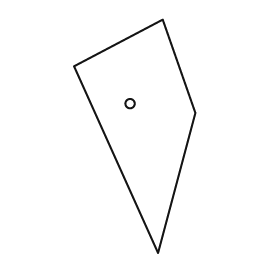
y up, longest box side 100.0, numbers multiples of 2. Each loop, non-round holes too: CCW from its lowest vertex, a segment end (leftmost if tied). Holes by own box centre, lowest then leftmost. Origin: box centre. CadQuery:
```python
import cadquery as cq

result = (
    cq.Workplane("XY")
    .moveTo(10.0, -50.0)
    .lineTo(26.0, 10.0)
    .lineTo(12.0, 50.0)
    .lineTo(-26.0, 30.0)
    .close()
    .moveTo(-2.0, 14.0)
    .circle(2.0)
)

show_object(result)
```